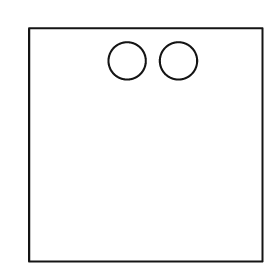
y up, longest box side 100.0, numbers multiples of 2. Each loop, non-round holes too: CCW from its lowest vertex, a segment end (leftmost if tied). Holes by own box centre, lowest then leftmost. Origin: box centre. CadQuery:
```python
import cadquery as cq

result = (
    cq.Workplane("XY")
    .moveTo(-50.0, -50.0)
    .lineTo(50.0, -50.0)
    .lineTo(50.0, 50.0)
    .lineTo(-50.0, 50.0)
    .close()
    .moveTo(-8.0, 36.0)
    .circle(8.0)
    .moveTo(14.0, 36.0)
    .circle(8.0)
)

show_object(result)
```